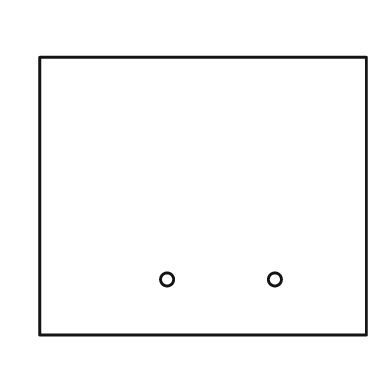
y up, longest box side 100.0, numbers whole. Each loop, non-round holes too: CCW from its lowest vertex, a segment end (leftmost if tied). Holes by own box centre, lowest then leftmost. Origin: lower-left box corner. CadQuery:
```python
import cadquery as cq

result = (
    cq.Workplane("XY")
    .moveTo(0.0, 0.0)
    .lineTo(100.0, 0.0)
    .lineTo(100.0, 85.0)
    .lineTo(0.0, 85.0)
    .close()
    .moveTo(39.0, 17.0)
    .circle(2.0)
    .moveTo(72.0, 17.0)
    .circle(2.0)
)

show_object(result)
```